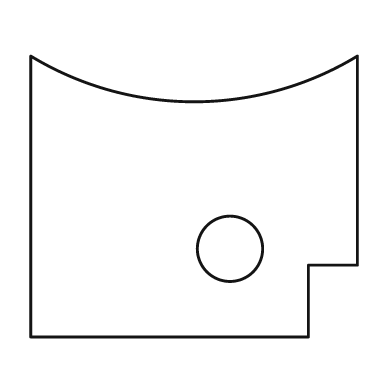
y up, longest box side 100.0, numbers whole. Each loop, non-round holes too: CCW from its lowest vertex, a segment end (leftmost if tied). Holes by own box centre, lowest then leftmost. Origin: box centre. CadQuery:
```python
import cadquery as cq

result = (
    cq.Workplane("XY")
    .moveTo(-50.0, -43.0)
    .lineTo(35.0, -43.0)
    .lineTo(35.0, -21.0)
    .lineTo(50.0, -21.0)
    .lineTo(50.0, 43.0)
    .threePointArc((0.0, 29.0), (-50.0, 43.0))
    .close()
    .moveTo(11.0, -16.0)
    .circle(10.0)
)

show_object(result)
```